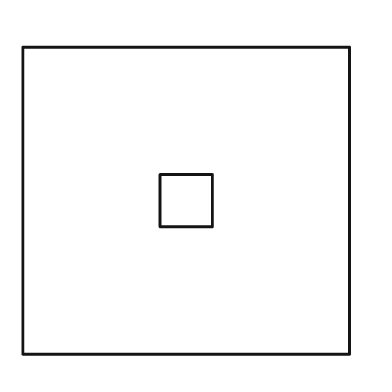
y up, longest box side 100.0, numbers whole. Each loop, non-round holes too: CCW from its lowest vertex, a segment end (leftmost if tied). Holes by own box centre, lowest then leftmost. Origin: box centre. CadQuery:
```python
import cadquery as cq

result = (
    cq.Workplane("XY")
    .moveTo(-50.0, -47.0)
    .lineTo(50.0, -47.0)
    .lineTo(50.0, 47.0)
    .lineTo(-50.0, 47.0)
    .close()
    .moveTo(-8.0, -8.0)
    .lineTo(8.0, -8.0)
    .lineTo(8.0, 8.0)
    .lineTo(-8.0, 8.0)
    .close()
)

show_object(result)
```